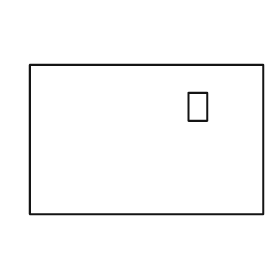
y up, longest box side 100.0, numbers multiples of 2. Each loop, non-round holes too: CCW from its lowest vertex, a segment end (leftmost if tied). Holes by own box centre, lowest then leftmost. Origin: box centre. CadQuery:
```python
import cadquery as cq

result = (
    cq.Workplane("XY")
    .moveTo(-50.0, -32.0)
    .lineTo(50.0, -32.0)
    .lineTo(50.0, 32.0)
    .lineTo(-50.0, 32.0)
    .close()
    .moveTo(18.0, 8.0)
    .lineTo(26.0, 8.0)
    .lineTo(26.0, 20.0)
    .lineTo(18.0, 20.0)
    .close()
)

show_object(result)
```